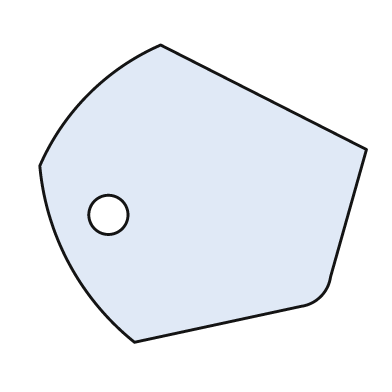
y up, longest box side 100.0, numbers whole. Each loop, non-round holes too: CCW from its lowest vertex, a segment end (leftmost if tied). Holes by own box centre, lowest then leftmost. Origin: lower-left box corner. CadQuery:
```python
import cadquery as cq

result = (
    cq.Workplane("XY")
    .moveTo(29.0, 0.0)
    .lineTo(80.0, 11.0)
    .threePointArc((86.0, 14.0), (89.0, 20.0))
    .lineTo(100.0, 59.0)
    .lineTo(37.0, 91.0)
    .threePointArc((15.0, 76.0), (0.0, 54.0))
    .threePointArc((9.0, 24.0), (29.0, 0.0))
    .close()
    .moveTo(21.0, 39.0)
    .circle(6.0)
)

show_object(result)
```